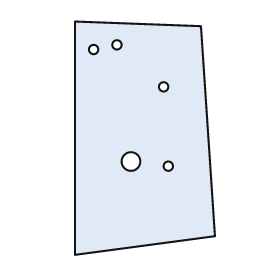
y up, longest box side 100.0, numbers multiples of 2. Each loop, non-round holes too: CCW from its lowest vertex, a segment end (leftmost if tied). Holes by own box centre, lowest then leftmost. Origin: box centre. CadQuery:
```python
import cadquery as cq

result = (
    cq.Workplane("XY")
    .moveTo(-30.0, -50.0)
    .lineTo(30.0, -42.0)
    .lineTo(24.0, 48.0)
    .lineTo(-30.0, 50.0)
    .close()
    .moveTo(10.0, -12.0)
    .circle(2.0)
    .moveTo(-6.0, -10.0)
    .circle(4.0)
    .moveTo(8.0, 22.0)
    .circle(2.0)
    .moveTo(-22.0, 38.0)
    .circle(2.0)
    .moveTo(-12.0, 40.0)
    .circle(2.0)
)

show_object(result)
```